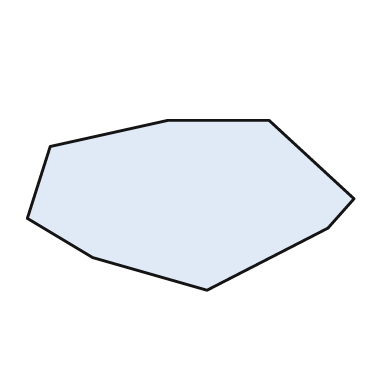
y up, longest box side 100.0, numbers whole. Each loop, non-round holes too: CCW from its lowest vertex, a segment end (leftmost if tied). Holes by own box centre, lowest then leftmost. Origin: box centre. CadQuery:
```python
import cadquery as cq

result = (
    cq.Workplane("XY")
    .moveTo(5.0, -26.0)
    .lineTo(42.0, -7.0)
    .lineTo(50.0, 2.0)
    .lineTo(24.0, 26.0)
    .lineTo(-7.0, 26.0)
    .lineTo(-43.0, 18.0)
    .lineTo(-50.0, -4.0)
    .lineTo(-30.0, -16.0)
    .close()
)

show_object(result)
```